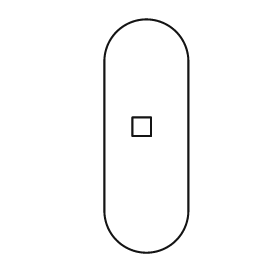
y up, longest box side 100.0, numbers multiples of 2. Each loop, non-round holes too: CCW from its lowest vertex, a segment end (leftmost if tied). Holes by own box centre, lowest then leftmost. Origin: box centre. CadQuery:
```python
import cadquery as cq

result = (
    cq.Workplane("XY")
    .moveTo(-18.0, -32.0)
    .threePointArc((0.0, -50.0), (18.0, -32.0))
    .lineTo(18.0, 32.0)
    .threePointArc((0.0, 50.0), (-18.0, 32.0))
    .close()
    .moveTo(-6.0, 0.0)
    .lineTo(2.0, 0.0)
    .lineTo(2.0, 8.0)
    .lineTo(-6.0, 8.0)
    .close()
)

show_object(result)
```